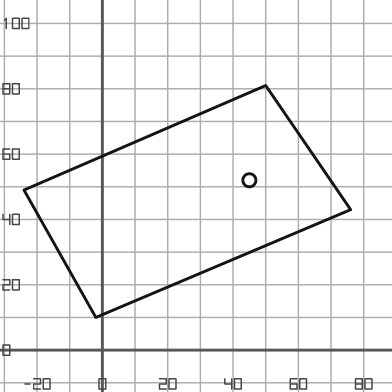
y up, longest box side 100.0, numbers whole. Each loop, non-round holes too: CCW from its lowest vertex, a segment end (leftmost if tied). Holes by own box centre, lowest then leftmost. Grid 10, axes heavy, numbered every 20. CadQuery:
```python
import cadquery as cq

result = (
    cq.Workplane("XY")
    .moveTo(-2.0, 10.0)
    .lineTo(76.0, 43.0)
    .lineTo(50.0, 81.0)
    .lineTo(-24.0, 49.0)
    .close()
    .moveTo(45.0, 52.0)
    .circle(2.0)
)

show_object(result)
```